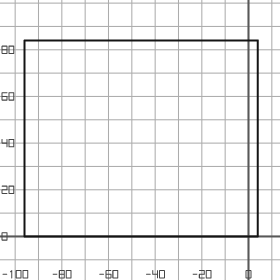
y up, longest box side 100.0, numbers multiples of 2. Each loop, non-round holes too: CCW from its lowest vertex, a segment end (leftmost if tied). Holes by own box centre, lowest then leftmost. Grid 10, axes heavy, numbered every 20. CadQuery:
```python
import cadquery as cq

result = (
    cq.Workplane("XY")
    .moveTo(-96.0, 0.0)
    .lineTo(4.0, 0.0)
    .lineTo(4.0, 84.0)
    .lineTo(-96.0, 84.0)
    .close()
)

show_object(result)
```